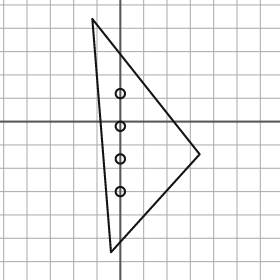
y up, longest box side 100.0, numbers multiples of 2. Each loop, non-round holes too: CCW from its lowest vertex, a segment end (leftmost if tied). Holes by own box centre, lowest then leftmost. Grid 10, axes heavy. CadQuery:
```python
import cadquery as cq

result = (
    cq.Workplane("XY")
    .moveTo(-4.0, -56.0)
    .lineTo(34.0, -14.0)
    .lineTo(-12.0, 44.0)
    .close()
    .moveTo(0.0, -30.0)
    .circle(2.0)
    .moveTo(0.0, -16.0)
    .circle(2.0)
    .moveTo(0.0, -2.0)
    .circle(2.0)
    .moveTo(0.0, 12.0)
    .circle(2.0)
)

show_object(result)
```